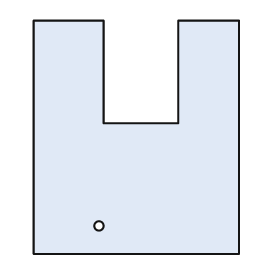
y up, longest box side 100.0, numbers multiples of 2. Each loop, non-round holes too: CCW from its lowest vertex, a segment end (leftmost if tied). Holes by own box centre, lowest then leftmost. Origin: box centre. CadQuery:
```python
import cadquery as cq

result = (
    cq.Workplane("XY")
    .moveTo(-44.0, -50.0)
    .lineTo(44.0, -50.0)
    .lineTo(44.0, 50.0)
    .lineTo(18.0, 50.0)
    .lineTo(18.0, 6.0)
    .lineTo(-14.0, 6.0)
    .lineTo(-14.0, 50.0)
    .lineTo(-44.0, 50.0)
    .close()
    .moveTo(-16.0, -38.0)
    .circle(2.0)
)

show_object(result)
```